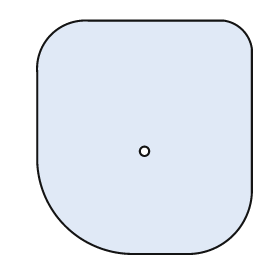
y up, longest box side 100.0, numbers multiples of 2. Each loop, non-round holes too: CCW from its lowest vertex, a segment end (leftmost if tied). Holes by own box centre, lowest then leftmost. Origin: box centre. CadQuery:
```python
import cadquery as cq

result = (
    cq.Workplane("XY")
    .moveTo(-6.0, -50.0)
    .lineTo(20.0, -50.0)
    .threePointArc((38.0, -42.0), (46.0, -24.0))
    .lineTo(46.0, 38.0)
    .threePointArc((42.0, 46.0), (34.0, 50.0))
    .lineTo(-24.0, 50.0)
    .threePointArc((-40.0, 44.0), (-46.0, 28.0))
    .lineTo(-46.0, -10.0)
    .threePointArc((-34.0, -38.0), (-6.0, -50.0))
    .close()
    .moveTo(0.0, -6.0)
    .circle(2.0)
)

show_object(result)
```